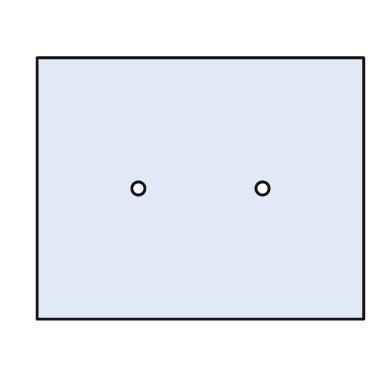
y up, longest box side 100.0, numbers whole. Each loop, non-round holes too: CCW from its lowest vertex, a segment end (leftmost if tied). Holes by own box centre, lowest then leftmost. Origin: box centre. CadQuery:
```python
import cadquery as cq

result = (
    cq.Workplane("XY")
    .moveTo(-50.0, -40.0)
    .lineTo(50.0, -40.0)
    .lineTo(50.0, 40.0)
    .lineTo(-50.0, 40.0)
    .close()
    .moveTo(-19.0, 0.0)
    .circle(2.0)
    .moveTo(19.0, 0.0)
    .circle(2.0)
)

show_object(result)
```